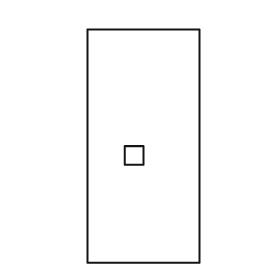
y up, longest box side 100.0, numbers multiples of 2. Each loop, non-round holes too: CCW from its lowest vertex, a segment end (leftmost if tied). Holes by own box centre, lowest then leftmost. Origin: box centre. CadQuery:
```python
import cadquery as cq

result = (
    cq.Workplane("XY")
    .moveTo(-24.0, -50.0)
    .lineTo(24.0, -50.0)
    .lineTo(24.0, 50.0)
    .lineTo(-24.0, 50.0)
    .close()
    .moveTo(-8.0, -8.0)
    .lineTo(0.0, -8.0)
    .lineTo(0.0, 0.0)
    .lineTo(-8.0, 0.0)
    .close()
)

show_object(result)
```